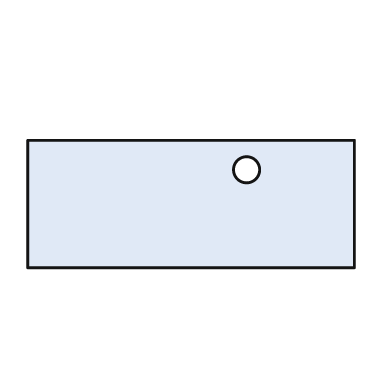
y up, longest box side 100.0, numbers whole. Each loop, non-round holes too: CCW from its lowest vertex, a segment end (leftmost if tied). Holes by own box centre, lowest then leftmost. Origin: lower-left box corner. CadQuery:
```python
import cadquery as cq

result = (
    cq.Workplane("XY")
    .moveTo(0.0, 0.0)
    .lineTo(100.0, 0.0)
    .lineTo(100.0, 39.0)
    .lineTo(0.0, 39.0)
    .close()
    .moveTo(67.0, 30.0)
    .circle(4.0)
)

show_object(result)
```